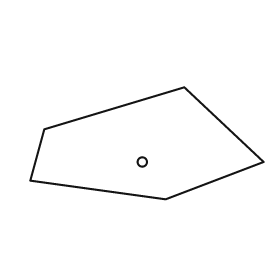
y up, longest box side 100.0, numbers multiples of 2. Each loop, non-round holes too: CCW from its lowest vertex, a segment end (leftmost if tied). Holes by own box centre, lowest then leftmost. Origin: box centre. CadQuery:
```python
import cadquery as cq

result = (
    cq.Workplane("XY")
    .moveTo(8.0, -24.0)
    .lineTo(50.0, -8.0)
    .lineTo(16.0, 24.0)
    .lineTo(-44.0, 6.0)
    .lineTo(-50.0, -16.0)
    .close()
    .moveTo(-2.0, -8.0)
    .circle(2.0)
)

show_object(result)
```